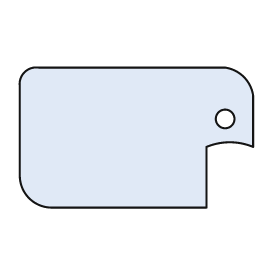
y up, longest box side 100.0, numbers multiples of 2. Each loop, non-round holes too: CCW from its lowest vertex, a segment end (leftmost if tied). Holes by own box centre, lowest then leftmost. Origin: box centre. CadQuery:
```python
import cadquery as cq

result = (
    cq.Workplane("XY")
    .moveTo(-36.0, -30.0)
    .lineTo(30.0, -30.0)
    .lineTo(30.0, -4.0)
    .threePointArc((40.0, -2.0), (50.0, -4.0))
    .lineTo(50.0, 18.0)
    .threePointArc((46.0, 26.0), (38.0, 30.0))
    .lineTo(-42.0, 30.0)
    .threePointArc((-48.0, 28.0), (-50.0, 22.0))
    .lineTo(-50.0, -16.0)
    .threePointArc((-46.0, -26.0), (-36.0, -30.0))
    .close()
    .moveTo(38.0, 8.0)
    .circle(4.0)
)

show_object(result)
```